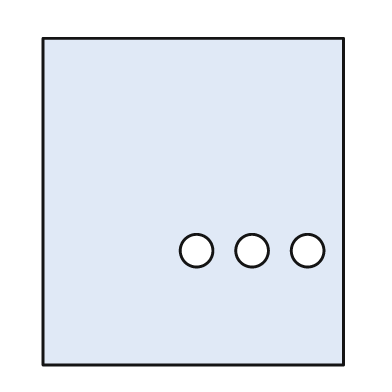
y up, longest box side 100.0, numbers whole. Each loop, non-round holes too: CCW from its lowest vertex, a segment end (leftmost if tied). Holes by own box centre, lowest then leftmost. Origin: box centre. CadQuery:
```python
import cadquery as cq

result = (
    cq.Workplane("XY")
    .moveTo(-46.0, -50.0)
    .lineTo(46.0, -50.0)
    .lineTo(46.0, 50.0)
    .lineTo(-46.0, 50.0)
    .close()
    .moveTo(1.0, -15.0)
    .circle(5.0)
    .moveTo(18.0, -15.0)
    .circle(5.0)
    .moveTo(35.0, -15.0)
    .circle(5.0)
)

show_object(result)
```